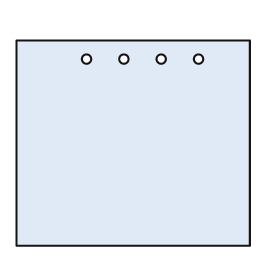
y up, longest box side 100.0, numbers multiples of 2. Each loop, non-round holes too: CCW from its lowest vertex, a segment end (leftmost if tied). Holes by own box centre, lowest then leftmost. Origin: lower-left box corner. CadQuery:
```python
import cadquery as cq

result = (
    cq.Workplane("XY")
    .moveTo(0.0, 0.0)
    .lineTo(100.0, 0.0)
    .lineTo(100.0, 88.0)
    .lineTo(0.0, 88.0)
    .close()
    .moveTo(30.0, 80.0)
    .circle(2.0)
    .moveTo(46.0, 80.0)
    .circle(2.0)
    .moveTo(62.0, 80.0)
    .circle(2.0)
    .moveTo(78.0, 80.0)
    .circle(2.0)
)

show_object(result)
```